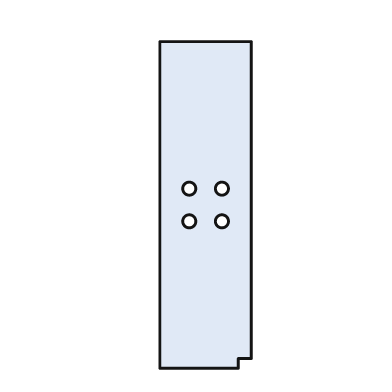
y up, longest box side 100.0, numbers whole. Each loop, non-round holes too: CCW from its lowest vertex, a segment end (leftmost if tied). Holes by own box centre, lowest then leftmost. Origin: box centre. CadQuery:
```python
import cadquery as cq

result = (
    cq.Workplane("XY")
    .moveTo(-14.0, -50.0)
    .lineTo(10.0, -50.0)
    .lineTo(10.0, -47.0)
    .lineTo(14.0, -47.0)
    .lineTo(14.0, 50.0)
    .lineTo(-14.0, 50.0)
    .close()
    .moveTo(-5.0, -5.0)
    .circle(2.0)
    .moveTo(5.0, -5.0)
    .circle(2.0)
    .moveTo(-5.0, 5.0)
    .circle(2.0)
    .moveTo(5.0, 5.0)
    .circle(2.0)
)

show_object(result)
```